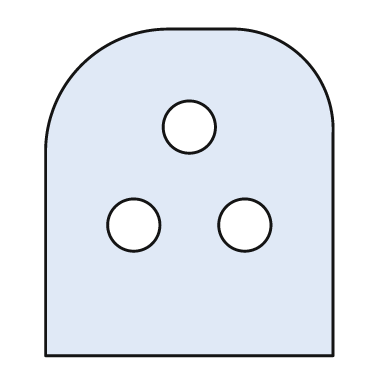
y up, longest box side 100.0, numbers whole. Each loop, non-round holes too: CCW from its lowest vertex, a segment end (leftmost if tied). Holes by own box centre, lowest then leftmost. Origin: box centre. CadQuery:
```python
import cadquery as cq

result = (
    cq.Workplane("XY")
    .moveTo(-44.0, -50.0)
    .lineTo(44.0, -50.0)
    .lineTo(44.0, 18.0)
    .threePointArc((35.0, 41.0), (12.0, 50.0))
    .lineTo(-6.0, 50.0)
    .threePointArc((-33.0, 39.0), (-44.0, 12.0))
    .close()
    .moveTo(-17.0, -10.0)
    .circle(8.0)
    .moveTo(17.0, -10.0)
    .circle(8.0)
    .moveTo(0.0, 20.0)
    .circle(8.0)
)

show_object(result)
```